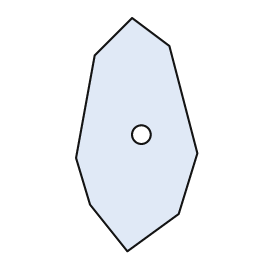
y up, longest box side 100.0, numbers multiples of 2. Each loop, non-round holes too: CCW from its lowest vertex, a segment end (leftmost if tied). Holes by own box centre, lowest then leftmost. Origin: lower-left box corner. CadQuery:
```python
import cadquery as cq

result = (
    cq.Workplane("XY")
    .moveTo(22.0, 0.0)
    .lineTo(44.0, 16.0)
    .lineTo(52.0, 42.0)
    .lineTo(40.0, 88.0)
    .lineTo(24.0, 100.0)
    .lineTo(8.0, 84.0)
    .lineTo(0.0, 40.0)
    .lineTo(6.0, 20.0)
    .close()
    .moveTo(28.0, 50.0)
    .circle(4.0)
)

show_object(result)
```